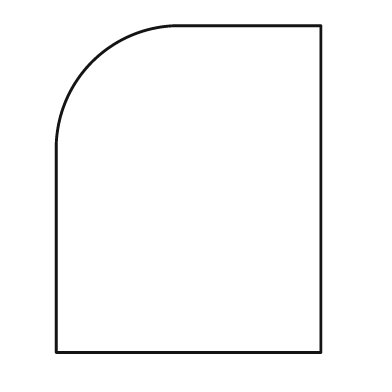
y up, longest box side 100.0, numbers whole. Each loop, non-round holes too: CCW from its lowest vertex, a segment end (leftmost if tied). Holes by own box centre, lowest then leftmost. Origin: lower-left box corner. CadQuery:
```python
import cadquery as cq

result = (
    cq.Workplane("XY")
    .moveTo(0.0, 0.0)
    .lineTo(81.0, 0.0)
    .lineTo(81.0, 100.0)
    .lineTo(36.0, 100.0)
    .threePointArc((11.0, 89.0), (0.0, 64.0))
    .close()
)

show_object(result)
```